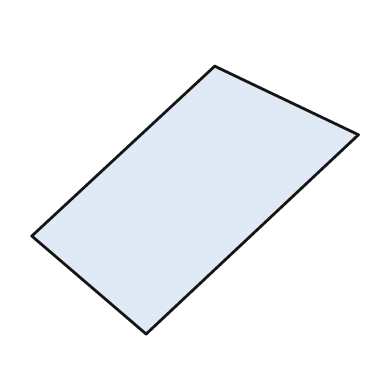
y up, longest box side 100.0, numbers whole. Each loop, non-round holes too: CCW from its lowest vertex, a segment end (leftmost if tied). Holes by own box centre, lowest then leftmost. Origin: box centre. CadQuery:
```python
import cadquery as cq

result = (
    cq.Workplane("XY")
    .moveTo(-15.0, -41.0)
    .lineTo(50.0, 20.0)
    .lineTo(6.0, 41.0)
    .lineTo(-50.0, -11.0)
    .close()
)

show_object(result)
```